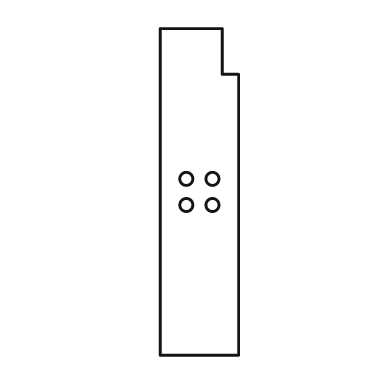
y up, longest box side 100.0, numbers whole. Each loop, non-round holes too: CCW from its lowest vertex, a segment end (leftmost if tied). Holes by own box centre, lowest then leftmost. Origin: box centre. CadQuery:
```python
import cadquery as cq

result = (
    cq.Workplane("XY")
    .moveTo(-12.0, -50.0)
    .lineTo(12.0, -50.0)
    .lineTo(12.0, 36.0)
    .lineTo(7.0, 36.0)
    .lineTo(7.0, 50.0)
    .lineTo(-12.0, 50.0)
    .close()
    .moveTo(-4.0, -4.0)
    .circle(2.0)
    .moveTo(4.0, -4.0)
    .circle(2.0)
    .moveTo(-4.0, 4.0)
    .circle(2.0)
    .moveTo(4.0, 4.0)
    .circle(2.0)
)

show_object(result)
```